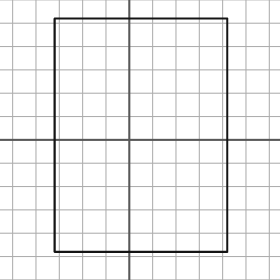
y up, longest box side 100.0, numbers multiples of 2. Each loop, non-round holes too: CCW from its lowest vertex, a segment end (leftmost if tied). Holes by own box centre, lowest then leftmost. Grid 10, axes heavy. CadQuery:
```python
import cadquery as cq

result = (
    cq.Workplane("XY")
    .moveTo(-32.0, -48.0)
    .lineTo(42.0, -48.0)
    .lineTo(42.0, 52.0)
    .lineTo(-32.0, 52.0)
    .close()
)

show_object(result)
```